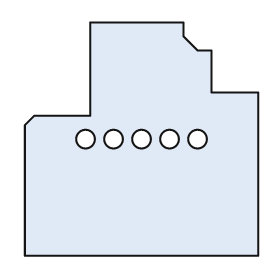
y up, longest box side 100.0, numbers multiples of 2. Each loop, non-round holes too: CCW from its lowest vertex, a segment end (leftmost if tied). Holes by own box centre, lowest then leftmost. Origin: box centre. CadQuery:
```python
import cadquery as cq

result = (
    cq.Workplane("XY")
    .moveTo(-50.0, -50.0)
    .lineTo(50.0, -50.0)
    .lineTo(50.0, 20.0)
    .lineTo(30.0, 20.0)
    .lineTo(30.0, 38.0)
    .lineTo(24.0, 38.0)
    .lineTo(18.0, 44.0)
    .lineTo(18.0, 50.0)
    .lineTo(-22.0, 50.0)
    .lineTo(-22.0, 10.0)
    .lineTo(-46.0, 10.0)
    .lineTo(-50.0, 6.0)
    .close()
    .moveTo(-24.0, 0.0)
    .circle(4.0)
    .moveTo(-12.0, 0.0)
    .circle(4.0)
    .moveTo(0.0, 0.0)
    .circle(4.0)
    .moveTo(12.0, 0.0)
    .circle(4.0)
    .moveTo(24.0, 0.0)
    .circle(4.0)
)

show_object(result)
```